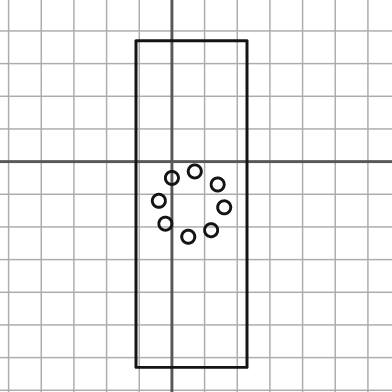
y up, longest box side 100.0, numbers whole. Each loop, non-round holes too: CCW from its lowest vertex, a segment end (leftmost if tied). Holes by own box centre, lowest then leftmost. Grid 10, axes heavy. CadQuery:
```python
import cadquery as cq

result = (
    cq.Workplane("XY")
    .moveTo(-11.0, -63.0)
    .lineTo(23.0, -63.0)
    .lineTo(23.0, 37.0)
    .lineTo(-11.0, 37.0)
    .close()
    .moveTo(5.0, -23.0)
    .circle(2.0)
    .moveTo(12.0, -21.0)
    .circle(2.0)
    .moveTo(-2.0, -19.0)
    .circle(2.0)
    .moveTo(16.0, -14.0)
    .circle(2.0)
    .moveTo(-4.0, -12.0)
    .circle(2.0)
    .moveTo(14.0, -7.0)
    .circle(2.0)
    .moveTo(0.0, -5.0)
    .circle(2.0)
    .moveTo(7.0, -3.0)
    .circle(2.0)
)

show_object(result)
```